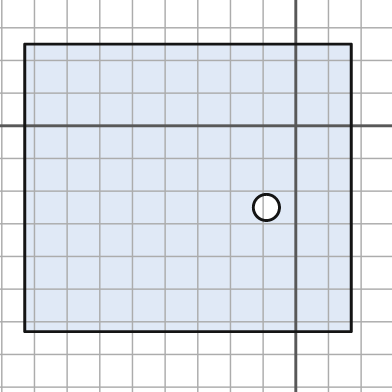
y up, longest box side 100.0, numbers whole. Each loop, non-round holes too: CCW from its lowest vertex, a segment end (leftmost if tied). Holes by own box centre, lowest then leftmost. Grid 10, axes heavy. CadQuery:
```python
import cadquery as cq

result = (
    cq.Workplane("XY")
    .moveTo(-83.0, -63.0)
    .lineTo(17.0, -63.0)
    .lineTo(17.0, 25.0)
    .lineTo(-83.0, 25.0)
    .close()
    .moveTo(-9.0, -25.0)
    .circle(4.0)
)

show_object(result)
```